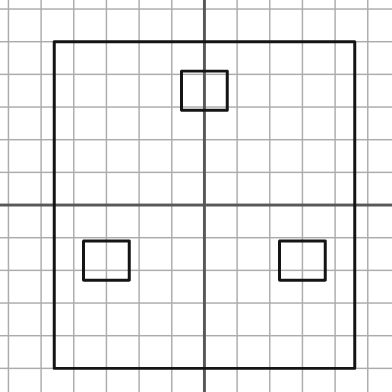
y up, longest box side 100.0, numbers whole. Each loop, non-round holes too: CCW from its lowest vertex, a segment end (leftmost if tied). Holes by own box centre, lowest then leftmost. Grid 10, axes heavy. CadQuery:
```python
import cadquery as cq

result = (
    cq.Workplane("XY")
    .moveTo(-46.0, -50.0)
    .lineTo(46.0, -50.0)
    .lineTo(46.0, 50.0)
    .lineTo(-46.0, 50.0)
    .close()
    .moveTo(-37.0, -23.0)
    .lineTo(-23.0, -23.0)
    .lineTo(-23.0, -11.0)
    .lineTo(-37.0, -11.0)
    .close()
    .moveTo(23.0, -23.0)
    .lineTo(37.0, -23.0)
    .lineTo(37.0, -11.0)
    .lineTo(23.0, -11.0)
    .close()
    .moveTo(-7.0, 29.0)
    .lineTo(7.0, 29.0)
    .lineTo(7.0, 41.0)
    .lineTo(-7.0, 41.0)
    .close()
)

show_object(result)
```